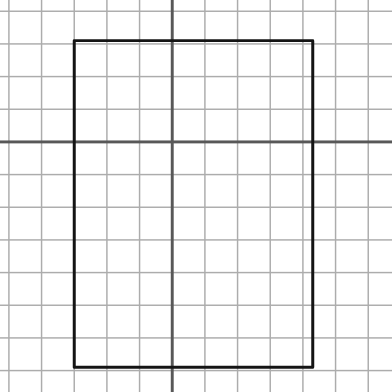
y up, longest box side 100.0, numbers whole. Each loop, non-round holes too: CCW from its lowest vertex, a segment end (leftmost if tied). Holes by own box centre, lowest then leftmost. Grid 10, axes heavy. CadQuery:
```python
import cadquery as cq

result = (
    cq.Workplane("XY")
    .moveTo(-30.0, -69.0)
    .lineTo(43.0, -69.0)
    .lineTo(43.0, 31.0)
    .lineTo(-30.0, 31.0)
    .close()
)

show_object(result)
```